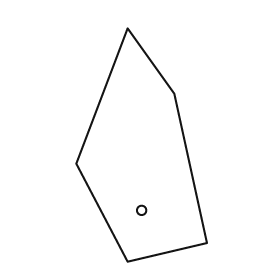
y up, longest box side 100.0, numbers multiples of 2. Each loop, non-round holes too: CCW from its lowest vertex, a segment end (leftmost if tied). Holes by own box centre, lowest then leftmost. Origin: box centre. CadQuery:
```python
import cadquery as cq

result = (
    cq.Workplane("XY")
    .moveTo(-6.0, -50.0)
    .lineTo(28.0, -42.0)
    .lineTo(14.0, 22.0)
    .lineTo(-6.0, 50.0)
    .lineTo(-28.0, -8.0)
    .close()
    .moveTo(0.0, -28.0)
    .circle(2.0)
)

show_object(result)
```